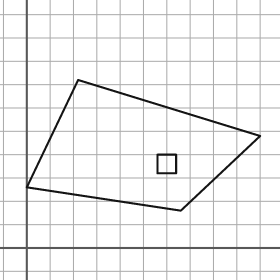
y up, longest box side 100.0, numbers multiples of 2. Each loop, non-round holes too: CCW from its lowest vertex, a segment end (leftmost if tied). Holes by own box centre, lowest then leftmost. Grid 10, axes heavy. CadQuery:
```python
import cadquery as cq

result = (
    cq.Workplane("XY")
    .moveTo(66.0, 16.0)
    .lineTo(100.0, 48.0)
    .lineTo(22.0, 72.0)
    .lineTo(0.0, 26.0)
    .close()
    .moveTo(56.0, 32.0)
    .lineTo(64.0, 32.0)
    .lineTo(64.0, 40.0)
    .lineTo(56.0, 40.0)
    .close()
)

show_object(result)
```